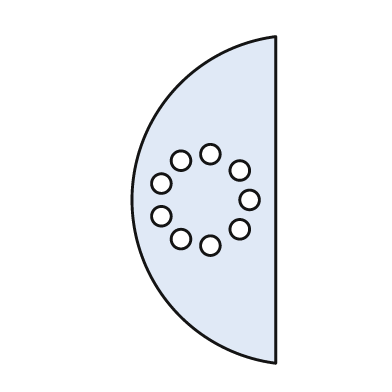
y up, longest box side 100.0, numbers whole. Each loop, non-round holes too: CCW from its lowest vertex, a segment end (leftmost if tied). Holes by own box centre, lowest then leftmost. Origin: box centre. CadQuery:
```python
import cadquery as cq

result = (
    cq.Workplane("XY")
    .moveTo(22.0, -50.0)
    .lineTo(22.0, 50.0)
    .threePointArc((-22.0, 0.0), (22.0, -50.0))
    .close()
    .moveTo(2.0, -14.0)
    .circle(3.0)
    .moveTo(-7.0, -12.0)
    .circle(3.0)
    .moveTo(11.0, -9.0)
    .circle(3.0)
    .moveTo(-13.0, -5.0)
    .circle(3.0)
    .moveTo(14.0, 0.0)
    .circle(3.0)
    .moveTo(-13.0, 5.0)
    .circle(3.0)
    .moveTo(11.0, 9.0)
    .circle(3.0)
    .moveTo(-7.0, 12.0)
    .circle(3.0)
    .moveTo(2.0, 14.0)
    .circle(3.0)
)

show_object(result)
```